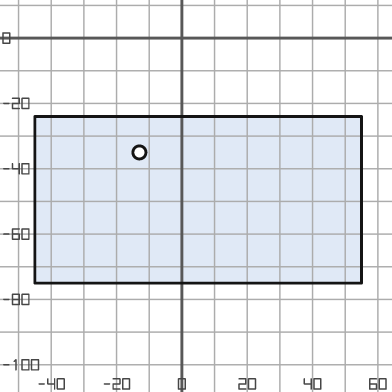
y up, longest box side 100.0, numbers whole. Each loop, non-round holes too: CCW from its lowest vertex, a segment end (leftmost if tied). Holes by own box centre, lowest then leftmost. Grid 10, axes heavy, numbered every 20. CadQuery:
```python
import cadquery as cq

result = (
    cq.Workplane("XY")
    .moveTo(-45.0, -75.0)
    .lineTo(55.0, -75.0)
    .lineTo(55.0, -24.0)
    .lineTo(-45.0, -24.0)
    .close()
    .moveTo(-13.0, -35.0)
    .circle(2.0)
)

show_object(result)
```